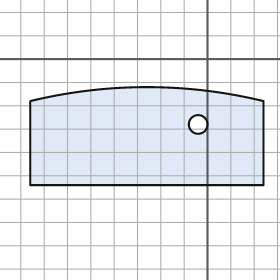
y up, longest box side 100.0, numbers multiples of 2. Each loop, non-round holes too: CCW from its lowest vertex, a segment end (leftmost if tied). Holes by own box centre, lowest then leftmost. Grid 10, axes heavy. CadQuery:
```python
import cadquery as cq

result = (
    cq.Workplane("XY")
    .moveTo(-76.0, -54.0)
    .lineTo(24.0, -54.0)
    .lineTo(24.0, -18.0)
    .threePointArc((-26.0, -12.0), (-76.0, -18.0))
    .close()
    .moveTo(-4.0, -28.0)
    .circle(4.0)
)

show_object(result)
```